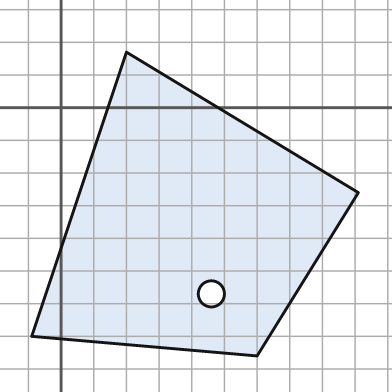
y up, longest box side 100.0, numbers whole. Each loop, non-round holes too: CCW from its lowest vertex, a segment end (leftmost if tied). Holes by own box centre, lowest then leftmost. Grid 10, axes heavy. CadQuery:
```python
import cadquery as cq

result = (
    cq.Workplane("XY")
    .moveTo(60.0, -76.0)
    .lineTo(91.0, -26.0)
    .lineTo(20.0, 17.0)
    .lineTo(-9.0, -70.0)
    .close()
    .moveTo(46.0, -57.0)
    .circle(4.0)
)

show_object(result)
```